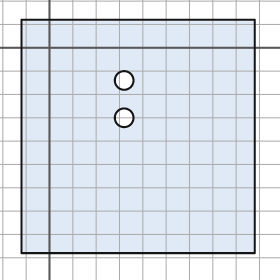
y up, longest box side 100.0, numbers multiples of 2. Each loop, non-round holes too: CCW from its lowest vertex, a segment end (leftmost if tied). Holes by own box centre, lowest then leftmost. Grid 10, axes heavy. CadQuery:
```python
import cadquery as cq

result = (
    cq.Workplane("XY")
    .moveTo(-12.0, -88.0)
    .lineTo(88.0, -88.0)
    .lineTo(88.0, 12.0)
    .lineTo(-12.0, 12.0)
    .close()
    .moveTo(32.0, -30.0)
    .circle(4.0)
    .moveTo(32.0, -14.0)
    .circle(4.0)
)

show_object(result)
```